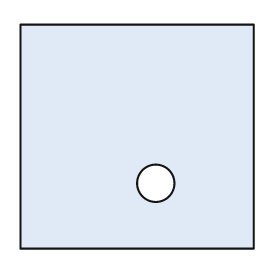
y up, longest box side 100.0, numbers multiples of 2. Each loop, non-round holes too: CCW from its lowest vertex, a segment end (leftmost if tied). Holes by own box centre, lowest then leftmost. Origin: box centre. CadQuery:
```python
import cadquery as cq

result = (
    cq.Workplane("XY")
    .moveTo(-50.0, -48.0)
    .lineTo(50.0, -48.0)
    .lineTo(50.0, 48.0)
    .lineTo(-50.0, 48.0)
    .close()
    .moveTo(8.0, -20.0)
    .circle(8.0)
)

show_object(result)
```